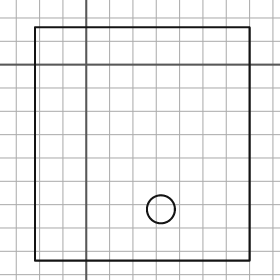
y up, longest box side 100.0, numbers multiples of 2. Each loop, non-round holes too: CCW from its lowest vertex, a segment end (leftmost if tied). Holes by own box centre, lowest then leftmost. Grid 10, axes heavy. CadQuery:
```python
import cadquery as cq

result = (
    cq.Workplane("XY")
    .moveTo(-22.0, -84.0)
    .lineTo(70.0, -84.0)
    .lineTo(70.0, 16.0)
    .lineTo(-22.0, 16.0)
    .close()
    .moveTo(32.0, -62.0)
    .circle(6.0)
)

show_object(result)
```